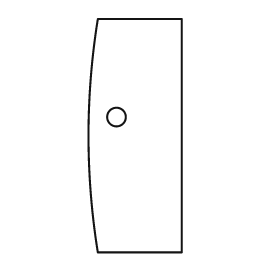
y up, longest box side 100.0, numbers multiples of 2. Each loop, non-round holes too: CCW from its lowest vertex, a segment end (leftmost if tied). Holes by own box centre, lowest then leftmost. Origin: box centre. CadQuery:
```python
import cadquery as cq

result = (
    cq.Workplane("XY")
    .moveTo(-16.0, -50.0)
    .lineTo(20.0, -50.0)
    .lineTo(20.0, 50.0)
    .lineTo(-16.0, 50.0)
    .threePointArc((-20.0, 0.0), (-16.0, -50.0))
    .close()
    .moveTo(-8.0, 8.0)
    .circle(4.0)
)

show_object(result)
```